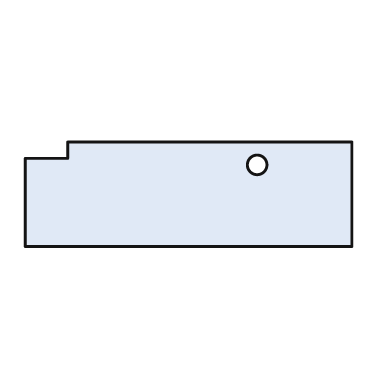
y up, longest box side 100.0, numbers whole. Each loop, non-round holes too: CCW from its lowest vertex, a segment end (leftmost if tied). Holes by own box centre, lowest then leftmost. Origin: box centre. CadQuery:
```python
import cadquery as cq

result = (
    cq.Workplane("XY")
    .moveTo(-50.0, -16.0)
    .lineTo(50.0, -16.0)
    .lineTo(50.0, 16.0)
    .lineTo(-37.0, 16.0)
    .lineTo(-37.0, 11.0)
    .lineTo(-50.0, 11.0)
    .close()
    .moveTo(21.0, 9.0)
    .circle(3.0)
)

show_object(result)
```